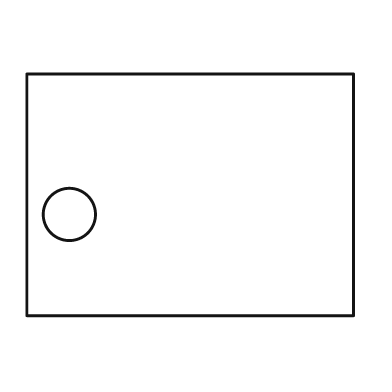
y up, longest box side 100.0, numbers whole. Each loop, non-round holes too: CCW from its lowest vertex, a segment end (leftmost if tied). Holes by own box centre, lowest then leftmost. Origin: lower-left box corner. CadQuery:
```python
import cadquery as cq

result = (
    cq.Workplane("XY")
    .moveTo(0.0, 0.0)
    .lineTo(100.0, 0.0)
    .lineTo(100.0, 74.0)
    .lineTo(0.0, 74.0)
    .close()
    .moveTo(13.0, 31.0)
    .circle(8.0)
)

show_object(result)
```